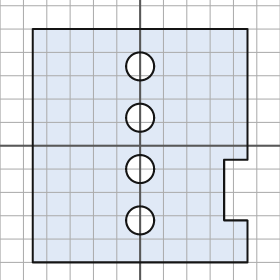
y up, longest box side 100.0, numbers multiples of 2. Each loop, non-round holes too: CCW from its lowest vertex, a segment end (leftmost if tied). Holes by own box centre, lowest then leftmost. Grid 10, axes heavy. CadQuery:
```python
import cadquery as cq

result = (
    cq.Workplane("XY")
    .moveTo(-46.0, -50.0)
    .lineTo(46.0, -50.0)
    .lineTo(46.0, -32.0)
    .lineTo(36.0, -32.0)
    .lineTo(36.0, -6.0)
    .lineTo(46.0, -6.0)
    .lineTo(46.0, 50.0)
    .lineTo(-46.0, 50.0)
    .close()
    .moveTo(0.0, -32.0)
    .circle(6.0)
    .moveTo(0.0, -10.0)
    .circle(6.0)
    .moveTo(0.0, 12.0)
    .circle(6.0)
    .moveTo(0.0, 34.0)
    .circle(6.0)
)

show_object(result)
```